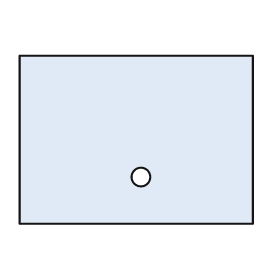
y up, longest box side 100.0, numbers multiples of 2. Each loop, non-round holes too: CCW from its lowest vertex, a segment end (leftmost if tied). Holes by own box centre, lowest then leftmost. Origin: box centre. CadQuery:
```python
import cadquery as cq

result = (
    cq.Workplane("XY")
    .moveTo(-50.0, -36.0)
    .lineTo(50.0, -36.0)
    .lineTo(50.0, 36.0)
    .lineTo(-50.0, 36.0)
    .close()
    .moveTo(2.0, -16.0)
    .circle(4.0)
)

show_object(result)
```